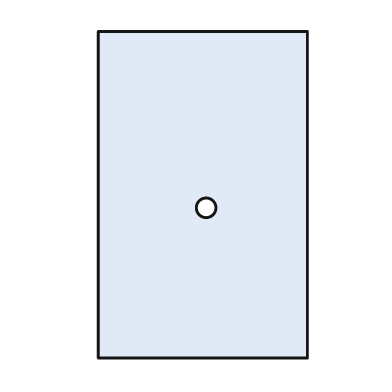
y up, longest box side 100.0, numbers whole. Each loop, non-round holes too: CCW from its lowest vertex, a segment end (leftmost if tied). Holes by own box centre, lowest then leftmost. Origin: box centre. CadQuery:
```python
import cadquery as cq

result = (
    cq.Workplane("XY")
    .moveTo(-32.0, -50.0)
    .lineTo(32.0, -50.0)
    .lineTo(32.0, 50.0)
    .lineTo(-32.0, 50.0)
    .close()
    .moveTo(1.0, -4.0)
    .circle(3.0)
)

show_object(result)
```